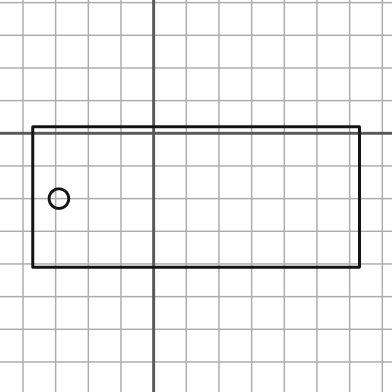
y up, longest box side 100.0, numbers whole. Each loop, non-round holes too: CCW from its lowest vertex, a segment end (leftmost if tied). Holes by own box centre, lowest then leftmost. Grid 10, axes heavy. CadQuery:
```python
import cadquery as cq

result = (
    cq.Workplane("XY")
    .moveTo(-37.0, -41.0)
    .lineTo(63.0, -41.0)
    .lineTo(63.0, 2.0)
    .lineTo(-37.0, 2.0)
    .close()
    .moveTo(-29.0, -20.0)
    .circle(3.0)
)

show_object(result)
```